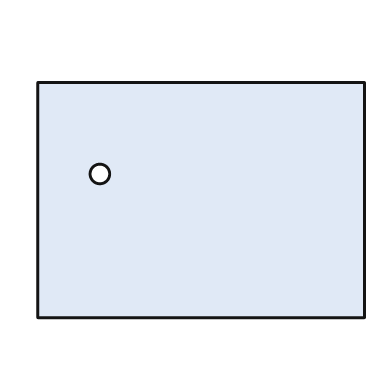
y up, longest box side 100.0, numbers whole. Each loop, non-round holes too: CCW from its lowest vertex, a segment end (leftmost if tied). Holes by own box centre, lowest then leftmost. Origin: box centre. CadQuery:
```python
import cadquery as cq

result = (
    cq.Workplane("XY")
    .moveTo(-50.0, -36.0)
    .lineTo(50.0, -36.0)
    .lineTo(50.0, 36.0)
    .lineTo(-50.0, 36.0)
    .close()
    .moveTo(-31.0, 8.0)
    .circle(3.0)
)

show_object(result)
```